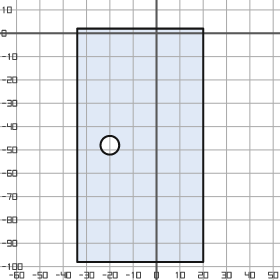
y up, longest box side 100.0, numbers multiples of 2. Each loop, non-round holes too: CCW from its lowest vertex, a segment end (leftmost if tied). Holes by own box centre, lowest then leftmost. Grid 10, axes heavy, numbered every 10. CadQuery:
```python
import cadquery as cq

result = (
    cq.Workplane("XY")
    .moveTo(-34.0, -98.0)
    .lineTo(20.0, -98.0)
    .lineTo(20.0, 2.0)
    .lineTo(-34.0, 2.0)
    .close()
    .moveTo(-20.0, -48.0)
    .circle(4.0)
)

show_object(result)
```